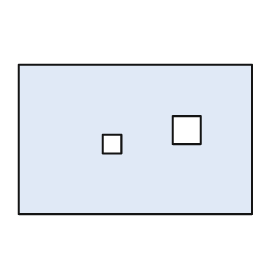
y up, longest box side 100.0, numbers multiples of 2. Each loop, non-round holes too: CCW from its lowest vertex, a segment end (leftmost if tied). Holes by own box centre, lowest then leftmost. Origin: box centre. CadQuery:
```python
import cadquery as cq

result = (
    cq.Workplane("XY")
    .moveTo(-50.0, -32.0)
    .lineTo(50.0, -32.0)
    .lineTo(50.0, 32.0)
    .lineTo(-50.0, 32.0)
    .close()
    .moveTo(-14.0, -6.0)
    .lineTo(-6.0, -6.0)
    .lineTo(-6.0, 2.0)
    .lineTo(-14.0, 2.0)
    .close()
    .moveTo(16.0, -2.0)
    .lineTo(28.0, -2.0)
    .lineTo(28.0, 10.0)
    .lineTo(16.0, 10.0)
    .close()
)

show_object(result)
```